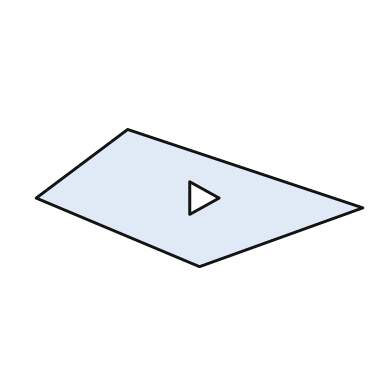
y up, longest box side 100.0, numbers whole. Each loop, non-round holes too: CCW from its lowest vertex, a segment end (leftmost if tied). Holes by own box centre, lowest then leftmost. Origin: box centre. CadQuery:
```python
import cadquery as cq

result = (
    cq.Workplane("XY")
    .moveTo(0.0, -21.0)
    .lineTo(50.0, -3.0)
    .lineTo(-22.0, 21.0)
    .lineTo(-50.0, 0.0)
    .close()
    .moveTo(-3.0, -5.0)
    .lineTo(6.0, 0.0)
    .lineTo(-3.0, 5.0)
    .close()
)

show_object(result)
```